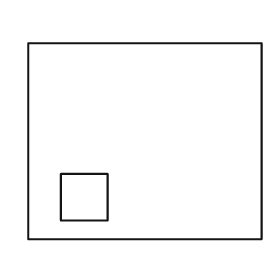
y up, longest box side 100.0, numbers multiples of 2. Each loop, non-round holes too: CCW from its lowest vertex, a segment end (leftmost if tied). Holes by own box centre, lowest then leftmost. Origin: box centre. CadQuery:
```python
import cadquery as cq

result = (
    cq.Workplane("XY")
    .moveTo(-50.0, -42.0)
    .lineTo(50.0, -42.0)
    .lineTo(50.0, 42.0)
    .lineTo(-50.0, 42.0)
    .close()
    .moveTo(-36.0, -34.0)
    .lineTo(-16.0, -34.0)
    .lineTo(-16.0, -14.0)
    .lineTo(-36.0, -14.0)
    .close()
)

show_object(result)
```